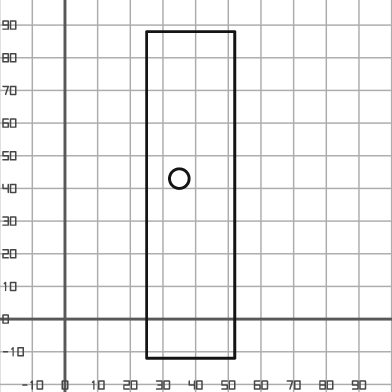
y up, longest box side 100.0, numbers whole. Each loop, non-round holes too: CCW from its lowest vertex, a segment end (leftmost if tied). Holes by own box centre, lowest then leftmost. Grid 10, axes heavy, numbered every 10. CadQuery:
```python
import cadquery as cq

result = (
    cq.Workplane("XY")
    .moveTo(25.0, -12.0)
    .lineTo(52.0, -12.0)
    .lineTo(52.0, 88.0)
    .lineTo(25.0, 88.0)
    .close()
    .moveTo(35.0, 43.0)
    .circle(3.0)
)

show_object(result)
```